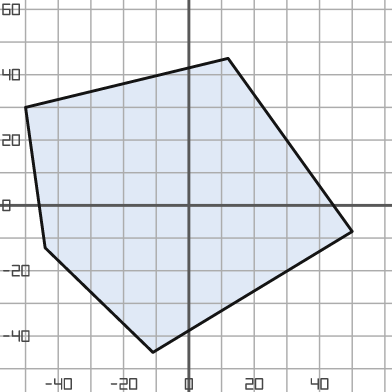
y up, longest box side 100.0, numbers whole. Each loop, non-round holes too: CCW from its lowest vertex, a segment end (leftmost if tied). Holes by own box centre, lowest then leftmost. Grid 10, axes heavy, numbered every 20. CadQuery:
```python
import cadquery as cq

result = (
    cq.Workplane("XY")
    .moveTo(-11.0, -45.0)
    .lineTo(50.0, -8.0)
    .lineTo(12.0, 45.0)
    .lineTo(-50.0, 30.0)
    .lineTo(-44.0, -13.0)
    .close()
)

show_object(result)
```